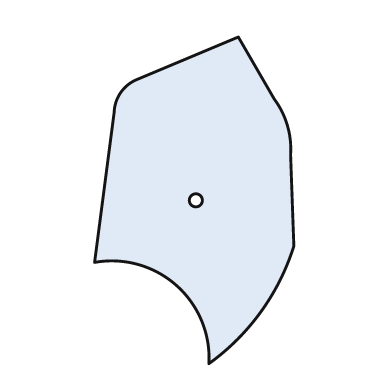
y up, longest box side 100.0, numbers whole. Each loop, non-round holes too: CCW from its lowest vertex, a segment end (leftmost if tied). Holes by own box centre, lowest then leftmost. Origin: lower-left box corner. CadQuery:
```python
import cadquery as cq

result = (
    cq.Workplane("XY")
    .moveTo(35.0, 0.0)
    .threePointArc((51.0, 16.0), (61.0, 36.0))
    .lineTo(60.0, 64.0)
    .threePointArc((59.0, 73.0), (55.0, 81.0))
    .lineTo(44.0, 100.0)
    .lineTo(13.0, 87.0)
    .threePointArc((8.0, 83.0), (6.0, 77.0))
    .lineTo(0.0, 31.0)
    .threePointArc((25.0, 24.0), (35.0, 0.0))
    .close()
    .moveTo(31.0, 50.0)
    .circle(2.0)
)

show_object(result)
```